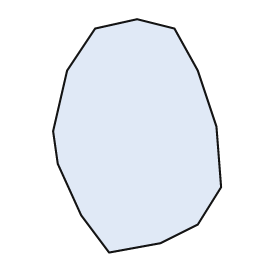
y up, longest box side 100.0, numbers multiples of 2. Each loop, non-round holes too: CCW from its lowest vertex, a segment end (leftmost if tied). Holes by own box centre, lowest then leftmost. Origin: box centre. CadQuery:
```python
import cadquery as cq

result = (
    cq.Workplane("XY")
    .moveTo(-12.0, -50.0)
    .lineTo(10.0, -46.0)
    .lineTo(26.0, -38.0)
    .lineTo(36.0, -22.0)
    .lineTo(34.0, 4.0)
    .lineTo(26.0, 28.0)
    .lineTo(16.0, 46.0)
    .lineTo(0.0, 50.0)
    .lineTo(-18.0, 46.0)
    .lineTo(-30.0, 28.0)
    .lineTo(-36.0, 2.0)
    .lineTo(-34.0, -12.0)
    .lineTo(-24.0, -34.0)
    .close()
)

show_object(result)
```